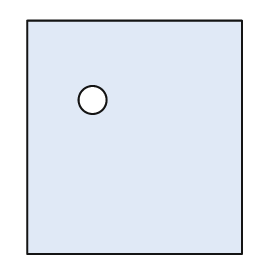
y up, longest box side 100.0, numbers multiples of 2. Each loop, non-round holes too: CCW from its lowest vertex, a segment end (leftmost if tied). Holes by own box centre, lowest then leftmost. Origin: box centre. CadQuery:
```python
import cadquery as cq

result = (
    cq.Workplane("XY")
    .moveTo(-46.0, -50.0)
    .lineTo(46.0, -50.0)
    .lineTo(46.0, 50.0)
    .lineTo(-46.0, 50.0)
    .close()
    .moveTo(-18.0, 16.0)
    .circle(6.0)
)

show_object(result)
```